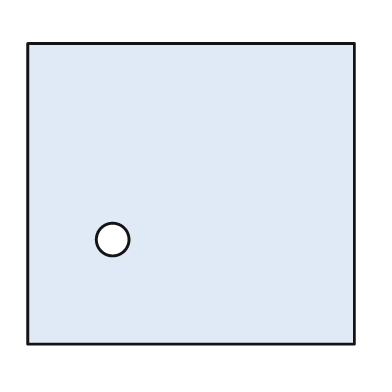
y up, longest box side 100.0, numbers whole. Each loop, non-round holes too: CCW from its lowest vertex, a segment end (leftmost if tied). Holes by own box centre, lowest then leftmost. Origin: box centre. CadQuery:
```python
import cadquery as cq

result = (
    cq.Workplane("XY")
    .moveTo(-50.0, -46.0)
    .lineTo(50.0, -46.0)
    .lineTo(50.0, 46.0)
    .lineTo(-50.0, 46.0)
    .close()
    .moveTo(-24.0, -14.0)
    .circle(5.0)
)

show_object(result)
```